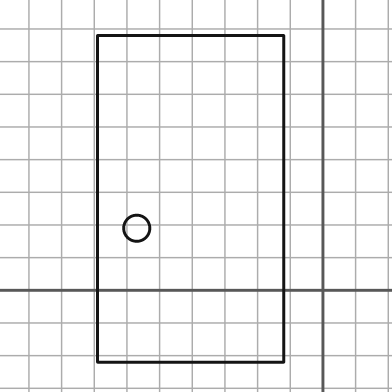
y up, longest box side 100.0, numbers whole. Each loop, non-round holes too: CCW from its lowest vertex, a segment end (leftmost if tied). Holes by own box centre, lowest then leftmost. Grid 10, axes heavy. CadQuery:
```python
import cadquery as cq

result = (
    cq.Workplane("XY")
    .moveTo(-69.0, -22.0)
    .lineTo(-12.0, -22.0)
    .lineTo(-12.0, 78.0)
    .lineTo(-69.0, 78.0)
    .close()
    .moveTo(-57.0, 19.0)
    .circle(4.0)
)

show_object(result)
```